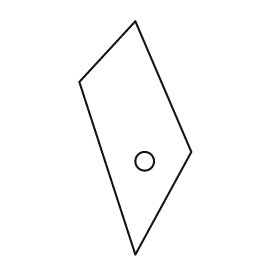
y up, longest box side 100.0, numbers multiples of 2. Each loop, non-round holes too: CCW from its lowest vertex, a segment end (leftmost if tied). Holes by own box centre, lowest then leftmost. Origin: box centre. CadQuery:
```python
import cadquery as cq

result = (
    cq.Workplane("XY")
    .moveTo(0.0, -50.0)
    .lineTo(24.0, -6.0)
    .lineTo(0.0, 50.0)
    .lineTo(-24.0, 24.0)
    .close()
    .moveTo(4.0, -10.0)
    .circle(4.0)
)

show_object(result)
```